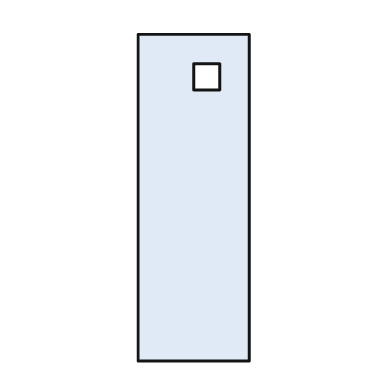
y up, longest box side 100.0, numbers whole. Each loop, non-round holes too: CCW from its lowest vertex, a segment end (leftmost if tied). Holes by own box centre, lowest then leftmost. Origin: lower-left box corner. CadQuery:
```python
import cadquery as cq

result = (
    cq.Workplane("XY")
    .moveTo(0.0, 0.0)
    .lineTo(34.0, 0.0)
    .lineTo(34.0, 100.0)
    .lineTo(0.0, 100.0)
    .close()
    .moveTo(17.0, 83.0)
    .lineTo(25.0, 83.0)
    .lineTo(25.0, 91.0)
    .lineTo(17.0, 91.0)
    .close()
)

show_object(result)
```